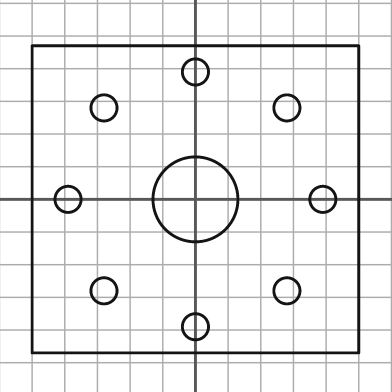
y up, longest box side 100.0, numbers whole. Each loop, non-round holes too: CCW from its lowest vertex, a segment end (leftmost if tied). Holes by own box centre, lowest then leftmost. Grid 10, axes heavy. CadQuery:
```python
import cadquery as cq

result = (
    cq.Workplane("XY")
    .moveTo(-50.0, -47.0)
    .lineTo(50.0, -47.0)
    .lineTo(50.0, 47.0)
    .lineTo(-50.0, 47.0)
    .close()
    .moveTo(0.0, -39.0)
    .circle(4.0)
    .moveTo(-28.0, -28.0)
    .circle(4.0)
    .moveTo(28.0, -28.0)
    .circle(4.0)
    .moveTo(-39.0, 0.0)
    .circle(4.0)
    .moveTo(0.0, 0.0)
    .circle(13.0)
    .moveTo(39.0, 0.0)
    .circle(4.0)
    .moveTo(-28.0, 28.0)
    .circle(4.0)
    .moveTo(28.0, 28.0)
    .circle(4.0)
    .moveTo(0.0, 39.0)
    .circle(4.0)
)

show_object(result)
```